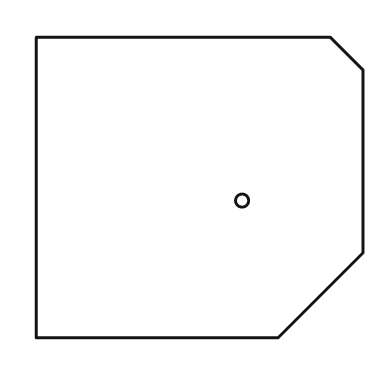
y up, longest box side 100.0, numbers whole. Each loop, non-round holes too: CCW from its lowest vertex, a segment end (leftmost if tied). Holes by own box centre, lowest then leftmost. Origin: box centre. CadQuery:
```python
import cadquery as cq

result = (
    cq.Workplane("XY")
    .moveTo(-50.0, -46.0)
    .lineTo(24.0, -46.0)
    .lineTo(50.0, -20.0)
    .lineTo(50.0, 36.0)
    .lineTo(40.0, 46.0)
    .lineTo(-50.0, 46.0)
    .close()
    .moveTo(13.0, -4.0)
    .circle(2.0)
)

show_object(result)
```